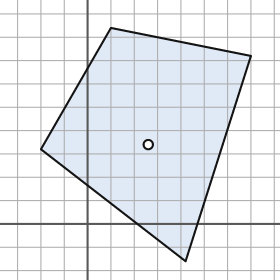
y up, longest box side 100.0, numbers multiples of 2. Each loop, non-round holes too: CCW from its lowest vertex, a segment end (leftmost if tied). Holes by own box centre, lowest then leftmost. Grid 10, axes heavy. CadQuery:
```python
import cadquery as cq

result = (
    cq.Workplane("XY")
    .moveTo(42.0, -16.0)
    .lineTo(70.0, 72.0)
    .lineTo(10.0, 84.0)
    .lineTo(-20.0, 32.0)
    .close()
    .moveTo(26.0, 34.0)
    .circle(2.0)
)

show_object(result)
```